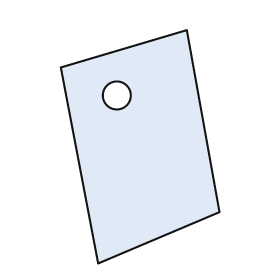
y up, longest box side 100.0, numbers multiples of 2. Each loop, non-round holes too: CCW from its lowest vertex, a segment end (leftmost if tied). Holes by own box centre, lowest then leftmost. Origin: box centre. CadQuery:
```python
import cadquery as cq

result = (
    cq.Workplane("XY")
    .moveTo(-18.0, -50.0)
    .lineTo(34.0, -28.0)
    .lineTo(20.0, 50.0)
    .lineTo(-34.0, 34.0)
    .close()
    .moveTo(-10.0, 22.0)
    .circle(6.0)
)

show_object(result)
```